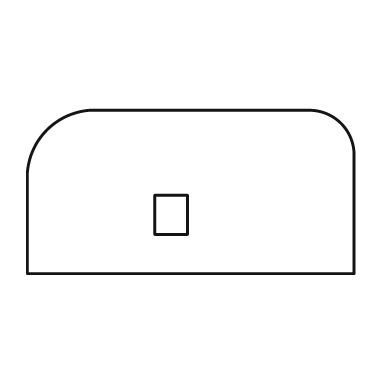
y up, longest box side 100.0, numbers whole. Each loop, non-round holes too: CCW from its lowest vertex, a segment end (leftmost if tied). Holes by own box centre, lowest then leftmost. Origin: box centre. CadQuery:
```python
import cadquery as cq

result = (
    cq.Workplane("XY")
    .moveTo(-50.0, -25.0)
    .lineTo(50.0, -25.0)
    .lineTo(50.0, 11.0)
    .threePointArc((46.0, 21.0), (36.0, 25.0))
    .lineTo(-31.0, 25.0)
    .threePointArc((-44.0, 19.0), (-50.0, 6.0))
    .close()
    .moveTo(-11.0, -13.0)
    .lineTo(-1.0, -13.0)
    .lineTo(-1.0, -1.0)
    .lineTo(-11.0, -1.0)
    .close()
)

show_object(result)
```